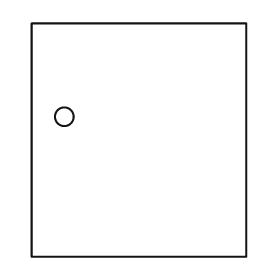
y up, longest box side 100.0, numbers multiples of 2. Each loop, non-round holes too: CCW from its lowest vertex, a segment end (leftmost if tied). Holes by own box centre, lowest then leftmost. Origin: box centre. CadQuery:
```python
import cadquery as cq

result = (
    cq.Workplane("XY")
    .moveTo(-46.0, -50.0)
    .lineTo(46.0, -50.0)
    .lineTo(46.0, 50.0)
    .lineTo(-46.0, 50.0)
    .close()
    .moveTo(-32.0, 10.0)
    .circle(4.0)
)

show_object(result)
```